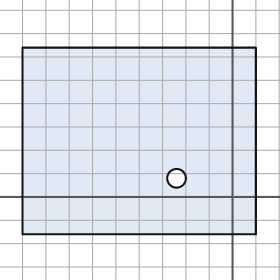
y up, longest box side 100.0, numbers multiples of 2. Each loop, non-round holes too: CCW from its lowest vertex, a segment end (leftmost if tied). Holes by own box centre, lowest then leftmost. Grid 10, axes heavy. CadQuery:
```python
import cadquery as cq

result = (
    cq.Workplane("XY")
    .moveTo(-90.0, -16.0)
    .lineTo(10.0, -16.0)
    .lineTo(10.0, 64.0)
    .lineTo(-90.0, 64.0)
    .close()
    .moveTo(-24.0, 8.0)
    .circle(4.0)
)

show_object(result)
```